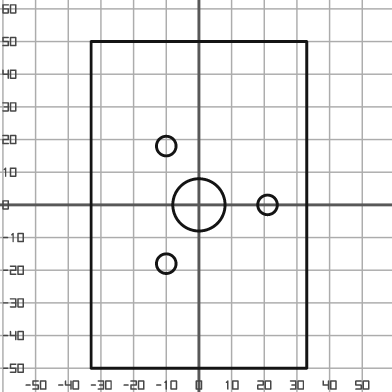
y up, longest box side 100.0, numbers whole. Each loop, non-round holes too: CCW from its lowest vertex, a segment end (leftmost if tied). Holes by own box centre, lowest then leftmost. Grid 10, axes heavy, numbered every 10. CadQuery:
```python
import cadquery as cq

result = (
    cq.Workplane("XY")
    .moveTo(-33.0, -50.0)
    .lineTo(33.0, -50.0)
    .lineTo(33.0, 50.0)
    .lineTo(-33.0, 50.0)
    .close()
    .moveTo(-10.0, -18.0)
    .circle(3.0)
    .moveTo(0.0, 0.0)
    .circle(8.0)
    .moveTo(21.0, 0.0)
    .circle(3.0)
    .moveTo(-10.0, 18.0)
    .circle(3.0)
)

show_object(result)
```